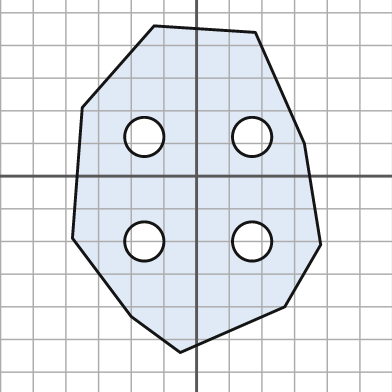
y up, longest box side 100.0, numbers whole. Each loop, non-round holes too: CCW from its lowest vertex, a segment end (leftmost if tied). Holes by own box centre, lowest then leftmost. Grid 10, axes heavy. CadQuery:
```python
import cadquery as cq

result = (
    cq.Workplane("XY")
    .moveTo(-5.0, -54.0)
    .lineTo(27.0, -40.0)
    .lineTo(38.0, -21.0)
    .lineTo(33.0, 10.0)
    .lineTo(18.0, 44.0)
    .lineTo(-13.0, 46.0)
    .lineTo(-35.0, 21.0)
    .lineTo(-38.0, -19.0)
    .lineTo(-20.0, -43.0)
    .close()
    .moveTo(-16.0, -20.0)
    .circle(6.0)
    .moveTo(17.0, -20.0)
    .circle(6.0)
    .moveTo(-16.0, 12.0)
    .circle(6.0)
    .moveTo(17.0, 12.0)
    .circle(6.0)
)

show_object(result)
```